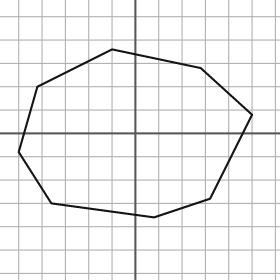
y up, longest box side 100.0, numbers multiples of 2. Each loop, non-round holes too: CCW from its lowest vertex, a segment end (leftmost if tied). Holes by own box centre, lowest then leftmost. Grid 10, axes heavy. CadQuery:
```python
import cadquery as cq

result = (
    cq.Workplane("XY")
    .moveTo(8.0, -36.0)
    .lineTo(32.0, -28.0)
    .lineTo(50.0, 8.0)
    .lineTo(28.0, 28.0)
    .lineTo(-10.0, 36.0)
    .lineTo(-42.0, 20.0)
    .lineTo(-50.0, -8.0)
    .lineTo(-36.0, -30.0)
    .close()
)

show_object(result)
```